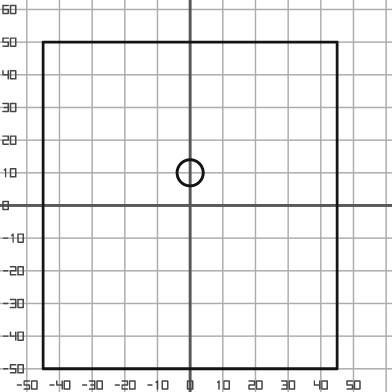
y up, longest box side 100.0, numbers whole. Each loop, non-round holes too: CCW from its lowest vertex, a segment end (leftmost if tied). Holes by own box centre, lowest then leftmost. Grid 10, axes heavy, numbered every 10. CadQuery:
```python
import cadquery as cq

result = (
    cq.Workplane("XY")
    .moveTo(-45.0, -50.0)
    .lineTo(45.0, -50.0)
    .lineTo(45.0, 50.0)
    .lineTo(-45.0, 50.0)
    .close()
    .moveTo(0.0, 10.0)
    .circle(4.0)
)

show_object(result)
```